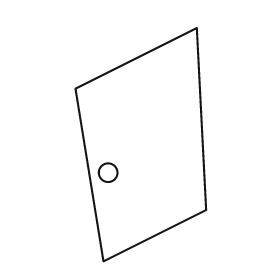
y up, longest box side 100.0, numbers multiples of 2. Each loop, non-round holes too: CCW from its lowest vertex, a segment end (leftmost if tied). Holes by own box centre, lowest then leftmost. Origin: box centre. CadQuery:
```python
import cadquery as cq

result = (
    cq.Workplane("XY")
    .moveTo(-16.0, -50.0)
    .lineTo(28.0, -28.0)
    .lineTo(24.0, 50.0)
    .lineTo(-28.0, 24.0)
    .close()
    .moveTo(-14.0, -12.0)
    .circle(4.0)
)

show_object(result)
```